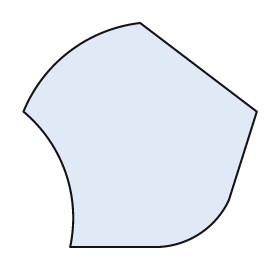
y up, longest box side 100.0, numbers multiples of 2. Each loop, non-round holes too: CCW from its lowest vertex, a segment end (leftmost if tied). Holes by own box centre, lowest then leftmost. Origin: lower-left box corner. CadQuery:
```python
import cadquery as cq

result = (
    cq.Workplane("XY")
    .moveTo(20.0, 0.0)
    .lineTo(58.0, 0.0)
    .threePointArc((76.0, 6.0), (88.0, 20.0))
    .lineTo(100.0, 58.0)
    .lineTo(50.0, 96.0)
    .threePointArc((20.0, 84.0), (0.0, 58.0))
    .threePointArc((18.0, 32.0), (20.0, 0.0))
    .close()
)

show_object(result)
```